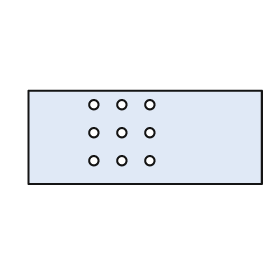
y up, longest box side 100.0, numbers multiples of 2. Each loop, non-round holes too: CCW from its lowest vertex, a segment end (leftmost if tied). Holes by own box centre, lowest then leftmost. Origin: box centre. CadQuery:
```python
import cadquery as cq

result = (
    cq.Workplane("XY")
    .moveTo(-50.0, -20.0)
    .lineTo(50.0, -20.0)
    .lineTo(50.0, 20.0)
    .lineTo(-50.0, 20.0)
    .close()
    .moveTo(-22.0, -10.0)
    .circle(2.0)
    .moveTo(-10.0, -10.0)
    .circle(2.0)
    .moveTo(2.0, -10.0)
    .circle(2.0)
    .moveTo(-22.0, 2.0)
    .circle(2.0)
    .moveTo(-10.0, 2.0)
    .circle(2.0)
    .moveTo(2.0, 2.0)
    .circle(2.0)
    .moveTo(-22.0, 14.0)
    .circle(2.0)
    .moveTo(-10.0, 14.0)
    .circle(2.0)
    .moveTo(2.0, 14.0)
    .circle(2.0)
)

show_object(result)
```